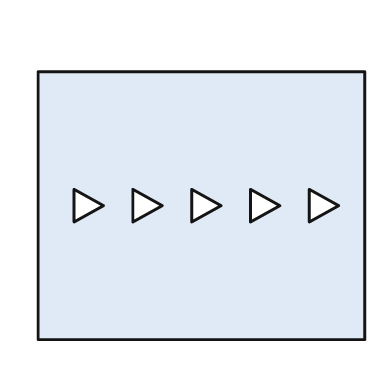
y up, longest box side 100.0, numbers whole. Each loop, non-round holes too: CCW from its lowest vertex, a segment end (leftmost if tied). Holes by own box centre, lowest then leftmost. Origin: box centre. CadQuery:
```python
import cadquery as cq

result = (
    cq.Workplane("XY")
    .moveTo(-50.0, -41.0)
    .lineTo(50.0, -41.0)
    .lineTo(50.0, 41.0)
    .lineTo(-50.0, 41.0)
    .close()
    .moveTo(-39.0, -5.0)
    .lineTo(-30.0, 0.0)
    .lineTo(-39.0, 5.0)
    .close()
    .moveTo(-21.0, -5.0)
    .lineTo(-12.0, 0.0)
    .lineTo(-21.0, 5.0)
    .close()
    .moveTo(-3.0, -5.0)
    .lineTo(6.0, 0.0)
    .lineTo(-3.0, 5.0)
    .close()
    .moveTo(15.0, -5.0)
    .lineTo(24.0, 0.0)
    .lineTo(15.0, 5.0)
    .close()
    .moveTo(33.0, -5.0)
    .lineTo(42.0, 0.0)
    .lineTo(33.0, 5.0)
    .close()
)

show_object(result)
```